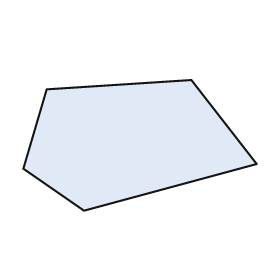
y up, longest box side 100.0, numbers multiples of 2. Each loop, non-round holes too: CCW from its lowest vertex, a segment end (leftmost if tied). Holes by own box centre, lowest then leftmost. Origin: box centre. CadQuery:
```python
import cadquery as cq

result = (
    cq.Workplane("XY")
    .moveTo(-24.0, -28.0)
    .lineTo(50.0, -8.0)
    .lineTo(22.0, 28.0)
    .lineTo(-40.0, 24.0)
    .lineTo(-50.0, -10.0)
    .close()
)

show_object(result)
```